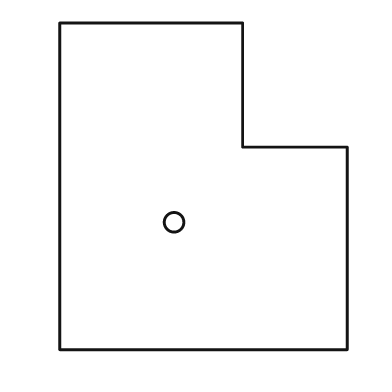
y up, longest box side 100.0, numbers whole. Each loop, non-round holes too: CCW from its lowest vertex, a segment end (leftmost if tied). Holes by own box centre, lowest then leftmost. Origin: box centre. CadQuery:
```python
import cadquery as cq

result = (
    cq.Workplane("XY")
    .moveTo(-44.0, -50.0)
    .lineTo(44.0, -50.0)
    .lineTo(44.0, 12.0)
    .lineTo(12.0, 12.0)
    .lineTo(12.0, 50.0)
    .lineTo(-44.0, 50.0)
    .close()
    .moveTo(-9.0, -11.0)
    .circle(3.0)
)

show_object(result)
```